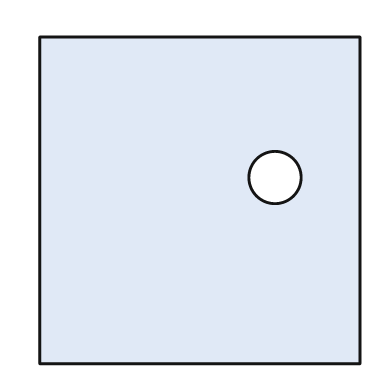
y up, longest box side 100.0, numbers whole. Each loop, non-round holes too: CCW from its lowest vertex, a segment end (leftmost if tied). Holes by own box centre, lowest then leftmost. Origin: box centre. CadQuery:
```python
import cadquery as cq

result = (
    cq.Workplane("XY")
    .moveTo(-49.0, -50.0)
    .lineTo(49.0, -50.0)
    .lineTo(49.0, 50.0)
    .lineTo(-49.0, 50.0)
    .close()
    .moveTo(23.0, 7.0)
    .circle(8.0)
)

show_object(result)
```